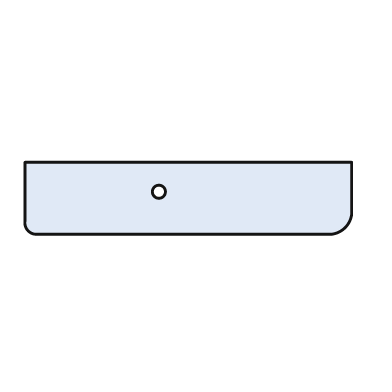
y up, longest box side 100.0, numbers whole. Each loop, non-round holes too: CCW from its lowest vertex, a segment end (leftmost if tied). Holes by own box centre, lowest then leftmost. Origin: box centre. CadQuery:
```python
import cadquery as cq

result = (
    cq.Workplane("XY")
    .moveTo(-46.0, -11.0)
    .lineTo(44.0, -11.0)
    .threePointArc((48.0, -9.0), (50.0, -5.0))
    .lineTo(50.0, 11.0)
    .lineTo(-50.0, 11.0)
    .lineTo(-50.0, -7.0)
    .threePointArc((-49.0, -10.0), (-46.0, -11.0))
    .close()
    .moveTo(-9.0, 2.0)
    .circle(2.0)
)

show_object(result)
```